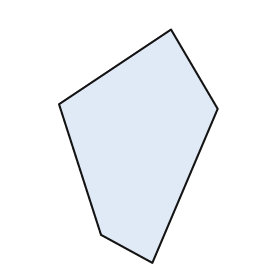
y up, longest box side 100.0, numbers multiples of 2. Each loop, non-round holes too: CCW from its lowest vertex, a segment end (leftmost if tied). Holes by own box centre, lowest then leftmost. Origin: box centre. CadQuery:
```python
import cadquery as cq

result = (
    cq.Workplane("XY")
    .moveTo(6.0, -50.0)
    .lineTo(34.0, 16.0)
    .lineTo(14.0, 50.0)
    .lineTo(-34.0, 18.0)
    .lineTo(-16.0, -38.0)
    .close()
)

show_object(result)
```